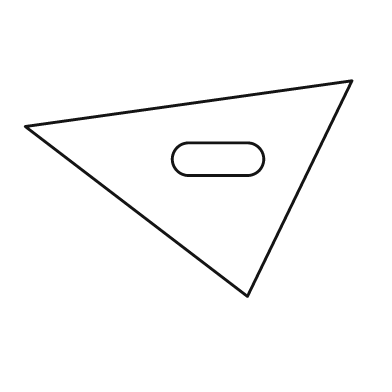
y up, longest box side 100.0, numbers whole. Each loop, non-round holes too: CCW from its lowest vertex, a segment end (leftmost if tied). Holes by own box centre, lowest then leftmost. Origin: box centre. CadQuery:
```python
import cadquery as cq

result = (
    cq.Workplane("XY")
    .moveTo(18.0, -33.0)
    .lineTo(50.0, 33.0)
    .lineTo(-50.0, 19.0)
    .close()
    .moveTo(0.0, 4.0)
    .lineTo(18.0, 4.0)
    .threePointArc((23.0, 9.0), (18.0, 14.0))
    .lineTo(0.0, 14.0)
    .threePointArc((-5.0, 9.0), (0.0, 4.0))
    .close()
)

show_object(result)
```